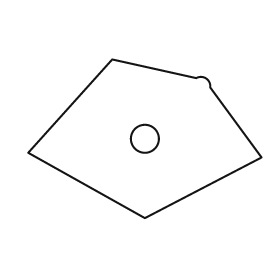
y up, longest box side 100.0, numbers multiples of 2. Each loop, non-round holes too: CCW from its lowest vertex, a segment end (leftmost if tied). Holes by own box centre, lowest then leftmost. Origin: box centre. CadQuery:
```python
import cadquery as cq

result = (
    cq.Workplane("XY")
    .moveTo(0.0, -34.0)
    .lineTo(50.0, -8.0)
    .lineTo(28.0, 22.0)
    .threePointArc((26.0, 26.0), (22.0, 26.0))
    .lineTo(-14.0, 34.0)
    .lineTo(-50.0, -6.0)
    .close()
    .moveTo(0.0, 0.0)
    .circle(6.0)
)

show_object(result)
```